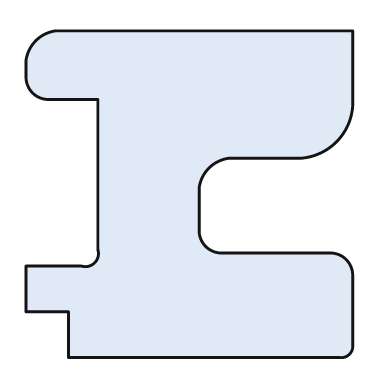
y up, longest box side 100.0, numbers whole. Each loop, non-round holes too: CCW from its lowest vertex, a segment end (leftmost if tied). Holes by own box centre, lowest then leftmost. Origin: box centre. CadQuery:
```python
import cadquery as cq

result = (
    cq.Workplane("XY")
    .moveTo(-37.0, -50.0)
    .lineTo(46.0, -50.0)
    .threePointArc((49.0, -49.0), (50.0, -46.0))
    .lineTo(50.0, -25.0)
    .threePointArc((48.0, -20.0), (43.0, -18.0))
    .lineTo(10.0, -18.0)
    .threePointArc((5.0, -16.0), (3.0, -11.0))
    .lineTo(3.0, 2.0)
    .threePointArc((6.0, 8.0), (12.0, 11.0))
    .lineTo(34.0, 11.0)
    .threePointArc((45.0, 16.0), (50.0, 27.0))
    .lineTo(50.0, 50.0)
    .lineTo(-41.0, 50.0)
    .threePointArc((-47.0, 47.0), (-50.0, 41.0))
    .lineTo(-50.0, 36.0)
    .threePointArc((-48.0, 31.0), (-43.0, 29.0))
    .lineTo(-28.0, 29.0)
    .lineTo(-28.0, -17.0)
    .threePointArc((-29.0, -21.0), (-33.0, -22.0))
    .lineTo(-50.0, -22.0)
    .lineTo(-50.0, -36.0)
    .lineTo(-37.0, -36.0)
    .close()
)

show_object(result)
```